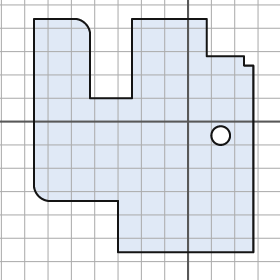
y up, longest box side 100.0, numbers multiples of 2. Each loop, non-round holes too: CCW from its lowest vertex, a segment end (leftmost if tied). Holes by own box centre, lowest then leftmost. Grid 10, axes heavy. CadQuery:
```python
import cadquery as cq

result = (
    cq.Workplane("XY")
    .moveTo(-30.0, -56.0)
    .lineTo(28.0, -56.0)
    .lineTo(28.0, 24.0)
    .lineTo(24.0, 24.0)
    .lineTo(24.0, 28.0)
    .lineTo(8.0, 28.0)
    .lineTo(8.0, 44.0)
    .lineTo(-24.0, 44.0)
    .lineTo(-24.0, 10.0)
    .lineTo(-42.0, 10.0)
    .lineTo(-42.0, 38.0)
    .threePointArc((-44.0, 42.0), (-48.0, 44.0))
    .lineTo(-66.0, 44.0)
    .lineTo(-66.0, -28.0)
    .threePointArc((-64.0, -32.0), (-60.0, -34.0))
    .lineTo(-30.0, -34.0)
    .close()
    .moveTo(14.0, -6.0)
    .circle(4.0)
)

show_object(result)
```